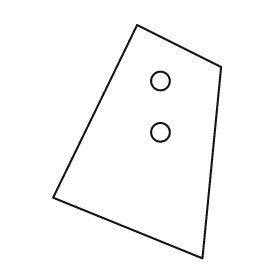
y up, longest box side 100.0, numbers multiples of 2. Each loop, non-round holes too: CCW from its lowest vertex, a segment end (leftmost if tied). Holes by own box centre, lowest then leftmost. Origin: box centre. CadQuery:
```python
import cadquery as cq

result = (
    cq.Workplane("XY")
    .moveTo(28.0, -50.0)
    .lineTo(36.0, 32.0)
    .lineTo(0.0, 50.0)
    .lineTo(-36.0, -24.0)
    .close()
    .moveTo(10.0, 4.0)
    .circle(4.0)
    .moveTo(10.0, 26.0)
    .circle(4.0)
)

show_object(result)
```